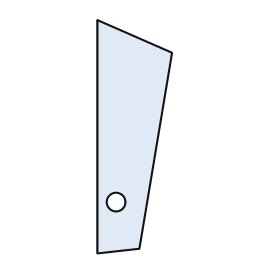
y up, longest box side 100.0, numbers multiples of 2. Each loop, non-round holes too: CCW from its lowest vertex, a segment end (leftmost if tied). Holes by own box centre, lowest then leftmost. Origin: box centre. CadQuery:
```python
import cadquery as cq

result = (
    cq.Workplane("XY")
    .moveTo(-16.0, -50.0)
    .lineTo(2.0, -48.0)
    .lineTo(16.0, 36.0)
    .lineTo(-16.0, 50.0)
    .close()
    .moveTo(-8.0, -28.0)
    .circle(4.0)
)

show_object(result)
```